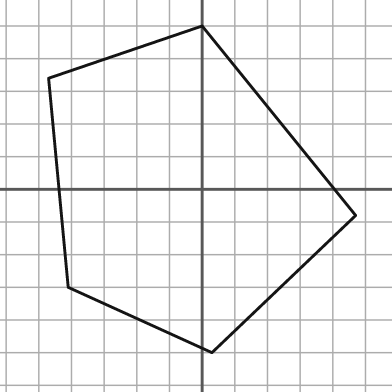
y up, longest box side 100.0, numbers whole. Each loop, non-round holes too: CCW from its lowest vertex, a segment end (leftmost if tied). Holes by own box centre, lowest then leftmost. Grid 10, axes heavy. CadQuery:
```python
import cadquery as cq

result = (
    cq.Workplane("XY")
    .moveTo(3.0, -50.0)
    .lineTo(47.0, -8.0)
    .lineTo(0.0, 50.0)
    .lineTo(-47.0, 34.0)
    .lineTo(-41.0, -30.0)
    .close()
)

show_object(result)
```